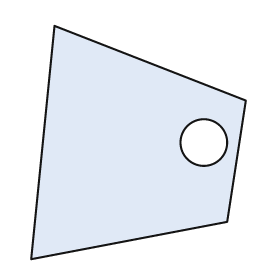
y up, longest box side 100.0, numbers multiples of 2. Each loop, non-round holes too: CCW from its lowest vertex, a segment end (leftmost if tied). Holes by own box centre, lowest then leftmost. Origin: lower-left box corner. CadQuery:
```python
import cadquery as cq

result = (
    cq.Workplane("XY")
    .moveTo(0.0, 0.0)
    .lineTo(84.0, 16.0)
    .lineTo(92.0, 68.0)
    .lineTo(10.0, 100.0)
    .close()
    .moveTo(74.0, 50.0)
    .circle(10.0)
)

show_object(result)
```